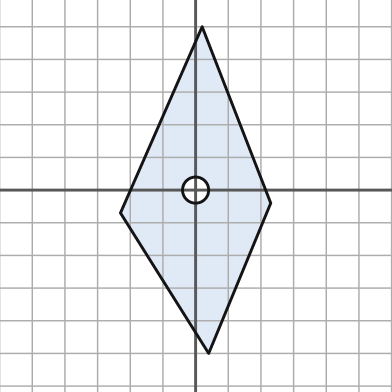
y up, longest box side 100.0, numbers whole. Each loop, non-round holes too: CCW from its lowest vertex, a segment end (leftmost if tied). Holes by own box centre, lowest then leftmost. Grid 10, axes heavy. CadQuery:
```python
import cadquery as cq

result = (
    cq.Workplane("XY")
    .moveTo(4.0, -50.0)
    .lineTo(23.0, -4.0)
    .lineTo(2.0, 50.0)
    .lineTo(-23.0, -7.0)
    .close()
    .moveTo(0.0, 0.0)
    .circle(4.0)
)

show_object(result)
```